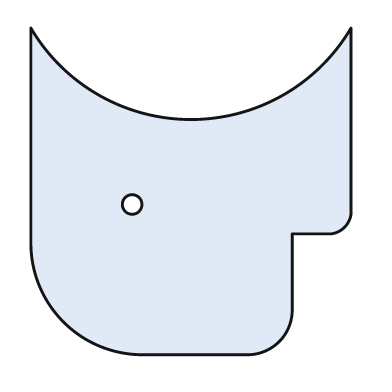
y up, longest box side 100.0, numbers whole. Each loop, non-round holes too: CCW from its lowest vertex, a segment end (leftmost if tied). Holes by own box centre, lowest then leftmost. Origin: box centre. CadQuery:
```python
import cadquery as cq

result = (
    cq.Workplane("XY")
    .moveTo(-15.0, -50.0)
    .lineTo(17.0, -50.0)
    .threePointArc((27.0, -46.0), (31.0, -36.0))
    .lineTo(31.0, -13.0)
    .lineTo(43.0, -13.0)
    .threePointArc((47.0, -11.0), (49.0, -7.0))
    .lineTo(49.0, 50.0)
    .threePointArc((0.0, 22.0), (-49.0, 50.0))
    .lineTo(-49.0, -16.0)
    .threePointArc((-39.0, -40.0), (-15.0, -50.0))
    .close()
    .moveTo(-18.0, -4.0)
    .circle(3.0)
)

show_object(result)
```